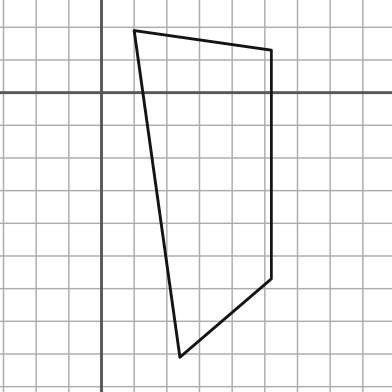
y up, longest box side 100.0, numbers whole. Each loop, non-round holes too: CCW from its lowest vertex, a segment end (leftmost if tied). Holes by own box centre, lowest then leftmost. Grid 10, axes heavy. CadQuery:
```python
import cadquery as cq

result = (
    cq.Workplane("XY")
    .moveTo(24.0, -81.0)
    .lineTo(52.0, -57.0)
    .lineTo(52.0, 13.0)
    .lineTo(10.0, 19.0)
    .close()
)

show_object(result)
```